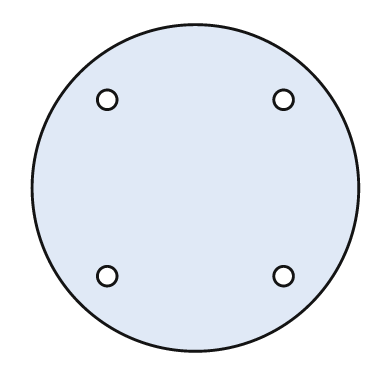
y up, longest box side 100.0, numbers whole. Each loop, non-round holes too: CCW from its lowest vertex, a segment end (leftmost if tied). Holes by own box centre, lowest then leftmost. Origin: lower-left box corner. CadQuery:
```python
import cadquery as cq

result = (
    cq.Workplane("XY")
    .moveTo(50.0, 50.0)
    .circle(50.0)
    .moveTo(23.0, 23.0)
    .circle(3.0)
    .moveTo(77.0, 23.0)
    .circle(3.0)
    .moveTo(23.0, 77.0)
    .circle(3.0)
    .moveTo(77.0, 77.0)
    .circle(3.0)
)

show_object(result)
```